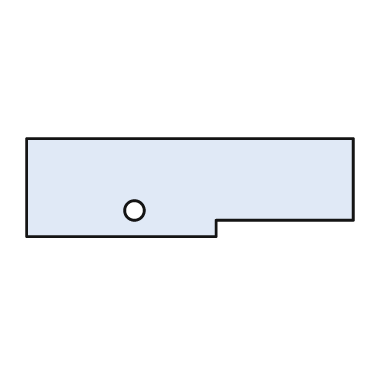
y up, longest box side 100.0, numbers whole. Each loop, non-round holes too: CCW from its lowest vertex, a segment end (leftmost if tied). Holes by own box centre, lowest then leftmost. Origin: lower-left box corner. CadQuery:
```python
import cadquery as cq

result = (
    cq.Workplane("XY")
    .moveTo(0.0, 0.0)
    .lineTo(58.0, 0.0)
    .lineTo(58.0, 5.0)
    .lineTo(100.0, 5.0)
    .lineTo(100.0, 30.0)
    .lineTo(0.0, 30.0)
    .close()
    .moveTo(33.0, 8.0)
    .circle(3.0)
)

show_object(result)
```